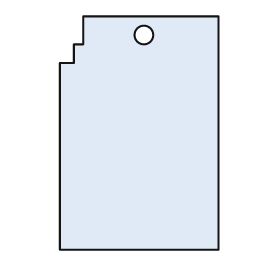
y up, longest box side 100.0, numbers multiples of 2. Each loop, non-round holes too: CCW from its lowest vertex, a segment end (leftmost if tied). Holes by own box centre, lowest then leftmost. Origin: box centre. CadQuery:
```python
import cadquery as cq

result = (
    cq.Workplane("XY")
    .moveTo(-34.0, -50.0)
    .lineTo(34.0, -50.0)
    .lineTo(34.0, 50.0)
    .lineTo(-24.0, 50.0)
    .lineTo(-24.0, 38.0)
    .lineTo(-28.0, 38.0)
    .lineTo(-28.0, 30.0)
    .lineTo(-34.0, 30.0)
    .close()
    .moveTo(2.0, 42.0)
    .circle(4.0)
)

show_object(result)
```